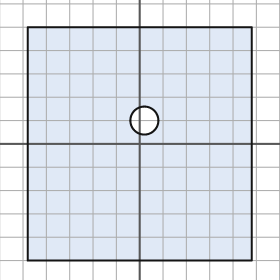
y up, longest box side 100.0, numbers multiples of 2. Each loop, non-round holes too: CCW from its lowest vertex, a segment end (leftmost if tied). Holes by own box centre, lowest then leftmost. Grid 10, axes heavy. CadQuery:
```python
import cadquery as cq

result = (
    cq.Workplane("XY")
    .moveTo(-48.0, -50.0)
    .lineTo(48.0, -50.0)
    .lineTo(48.0, 50.0)
    .lineTo(-48.0, 50.0)
    .close()
    .moveTo(2.0, 10.0)
    .circle(6.0)
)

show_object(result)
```